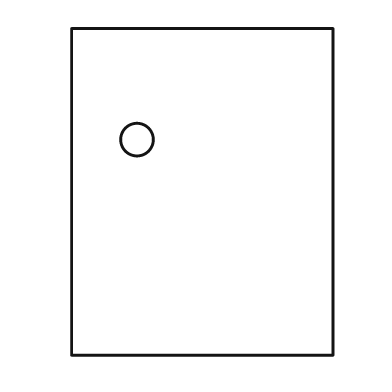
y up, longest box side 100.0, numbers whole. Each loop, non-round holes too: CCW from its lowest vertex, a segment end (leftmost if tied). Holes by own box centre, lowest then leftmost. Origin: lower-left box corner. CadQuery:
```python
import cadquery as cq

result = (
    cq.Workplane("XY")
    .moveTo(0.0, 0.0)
    .lineTo(80.0, 0.0)
    .lineTo(80.0, 100.0)
    .lineTo(0.0, 100.0)
    .close()
    .moveTo(20.0, 66.0)
    .circle(5.0)
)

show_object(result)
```